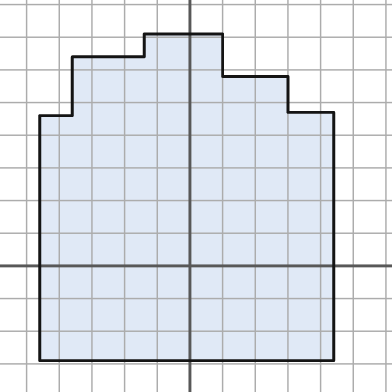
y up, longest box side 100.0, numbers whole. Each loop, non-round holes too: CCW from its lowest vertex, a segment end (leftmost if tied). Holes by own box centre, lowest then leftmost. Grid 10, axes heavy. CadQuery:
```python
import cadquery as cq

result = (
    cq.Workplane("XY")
    .moveTo(-46.0, -29.0)
    .lineTo(44.0, -29.0)
    .lineTo(44.0, 47.0)
    .lineTo(30.0, 47.0)
    .lineTo(30.0, 58.0)
    .lineTo(10.0, 58.0)
    .lineTo(10.0, 71.0)
    .lineTo(-14.0, 71.0)
    .lineTo(-14.0, 64.0)
    .lineTo(-36.0, 64.0)
    .lineTo(-36.0, 46.0)
    .lineTo(-46.0, 46.0)
    .close()
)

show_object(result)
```